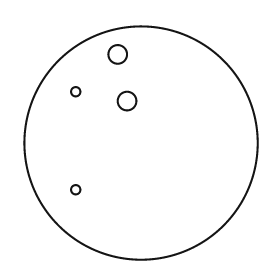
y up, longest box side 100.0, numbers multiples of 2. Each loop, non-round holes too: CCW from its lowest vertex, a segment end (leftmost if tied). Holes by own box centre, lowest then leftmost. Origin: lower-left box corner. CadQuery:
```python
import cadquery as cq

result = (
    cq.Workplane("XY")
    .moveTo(50.0, 50.0)
    .circle(50.0)
    .moveTo(22.0, 30.0)
    .circle(2.0)
    .moveTo(44.0, 68.0)
    .circle(4.0)
    .moveTo(22.0, 72.0)
    .circle(2.0)
    .moveTo(40.0, 88.0)
    .circle(4.0)
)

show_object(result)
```